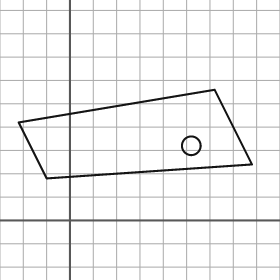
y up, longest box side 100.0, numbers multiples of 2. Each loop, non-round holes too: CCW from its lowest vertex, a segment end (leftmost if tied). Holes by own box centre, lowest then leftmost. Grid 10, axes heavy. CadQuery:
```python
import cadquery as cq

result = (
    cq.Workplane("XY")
    .moveTo(-10.0, 18.0)
    .lineTo(78.0, 24.0)
    .lineTo(62.0, 56.0)
    .lineTo(-22.0, 42.0)
    .close()
    .moveTo(52.0, 32.0)
    .circle(4.0)
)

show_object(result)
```